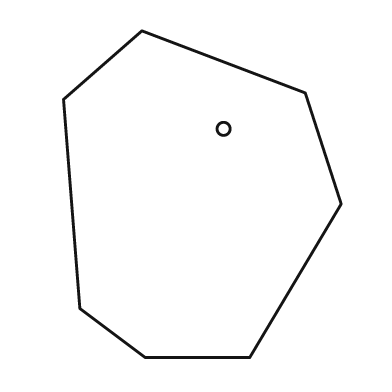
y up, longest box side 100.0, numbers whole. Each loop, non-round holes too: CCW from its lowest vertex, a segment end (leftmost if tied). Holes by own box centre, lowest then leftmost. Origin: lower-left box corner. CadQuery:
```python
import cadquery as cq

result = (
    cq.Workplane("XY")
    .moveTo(25.0, 0.0)
    .lineTo(57.0, 0.0)
    .lineTo(85.0, 47.0)
    .lineTo(74.0, 81.0)
    .lineTo(24.0, 100.0)
    .lineTo(0.0, 79.0)
    .lineTo(5.0, 15.0)
    .close()
    .moveTo(49.0, 70.0)
    .circle(2.0)
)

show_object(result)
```